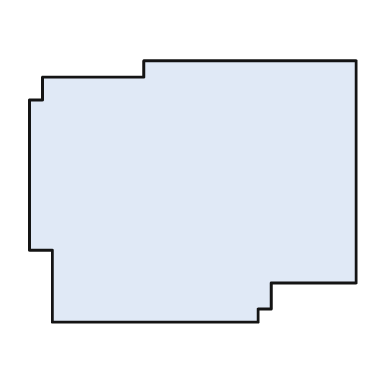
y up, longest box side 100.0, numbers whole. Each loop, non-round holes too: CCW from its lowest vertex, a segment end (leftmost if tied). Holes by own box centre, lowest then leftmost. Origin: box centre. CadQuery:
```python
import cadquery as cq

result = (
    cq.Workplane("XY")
    .moveTo(-43.0, -40.0)
    .lineTo(20.0, -40.0)
    .lineTo(20.0, -36.0)
    .lineTo(24.0, -36.0)
    .lineTo(24.0, -28.0)
    .lineTo(50.0, -28.0)
    .lineTo(50.0, 40.0)
    .lineTo(-15.0, 40.0)
    .lineTo(-15.0, 35.0)
    .lineTo(-46.0, 35.0)
    .lineTo(-46.0, 28.0)
    .lineTo(-50.0, 28.0)
    .lineTo(-50.0, -18.0)
    .lineTo(-43.0, -18.0)
    .close()
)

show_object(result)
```